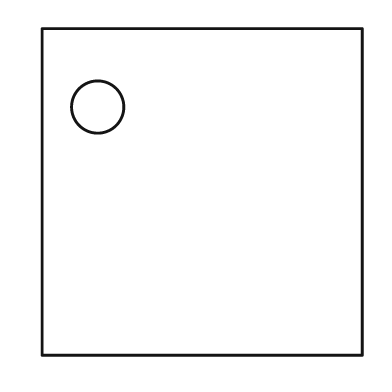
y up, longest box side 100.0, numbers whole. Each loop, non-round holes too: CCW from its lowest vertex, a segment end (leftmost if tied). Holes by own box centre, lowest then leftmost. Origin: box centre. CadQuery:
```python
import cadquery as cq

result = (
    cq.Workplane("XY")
    .moveTo(-49.0, -50.0)
    .lineTo(49.0, -50.0)
    .lineTo(49.0, 50.0)
    .lineTo(-49.0, 50.0)
    .close()
    .moveTo(-32.0, 26.0)
    .circle(8.0)
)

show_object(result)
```